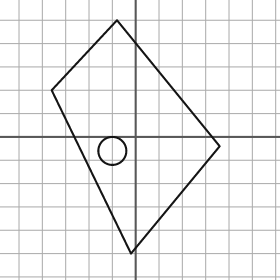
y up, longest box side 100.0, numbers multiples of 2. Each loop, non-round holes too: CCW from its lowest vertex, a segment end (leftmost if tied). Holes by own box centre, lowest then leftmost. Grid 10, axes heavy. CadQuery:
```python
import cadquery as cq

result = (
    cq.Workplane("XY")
    .moveTo(-2.0, -50.0)
    .lineTo(36.0, -4.0)
    .lineTo(-8.0, 50.0)
    .lineTo(-36.0, 20.0)
    .close()
    .moveTo(-10.0, -6.0)
    .circle(6.0)
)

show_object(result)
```